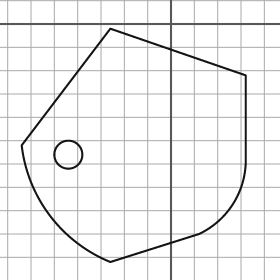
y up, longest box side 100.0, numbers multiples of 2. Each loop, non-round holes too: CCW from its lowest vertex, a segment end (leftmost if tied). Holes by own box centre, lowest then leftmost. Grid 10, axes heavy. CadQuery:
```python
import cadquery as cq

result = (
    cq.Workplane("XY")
    .moveTo(-26.0, -102.0)
    .lineTo(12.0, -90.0)
    .threePointArc((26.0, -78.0), (32.0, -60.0))
    .lineTo(32.0, -22.0)
    .lineTo(-26.0, -2.0)
    .lineTo(-64.0, -52.0)
    .threePointArc((-52.0, -82.0), (-26.0, -102.0))
    .close()
    .moveTo(-44.0, -56.0)
    .circle(6.0)
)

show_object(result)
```